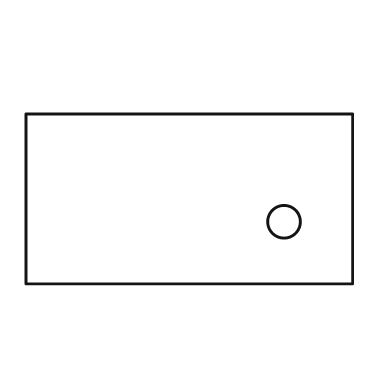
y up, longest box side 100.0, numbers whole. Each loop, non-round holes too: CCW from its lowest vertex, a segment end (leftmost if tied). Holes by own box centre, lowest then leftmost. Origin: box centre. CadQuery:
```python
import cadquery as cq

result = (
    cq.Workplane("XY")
    .moveTo(-50.0, -26.0)
    .lineTo(50.0, -26.0)
    .lineTo(50.0, 26.0)
    .lineTo(-50.0, 26.0)
    .close()
    .moveTo(29.0, -7.0)
    .circle(5.0)
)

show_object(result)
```